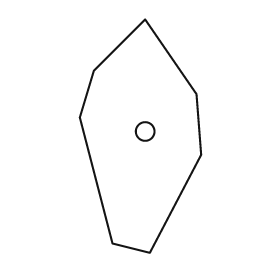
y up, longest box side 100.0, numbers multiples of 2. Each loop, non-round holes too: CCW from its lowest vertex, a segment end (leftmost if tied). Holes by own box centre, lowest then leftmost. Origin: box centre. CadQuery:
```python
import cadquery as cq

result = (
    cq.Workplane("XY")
    .moveTo(4.0, -50.0)
    .lineTo(26.0, -8.0)
    .lineTo(24.0, 18.0)
    .lineTo(2.0, 50.0)
    .lineTo(-20.0, 28.0)
    .lineTo(-26.0, 8.0)
    .lineTo(-12.0, -46.0)
    .close()
    .moveTo(2.0, 2.0)
    .circle(4.0)
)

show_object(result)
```